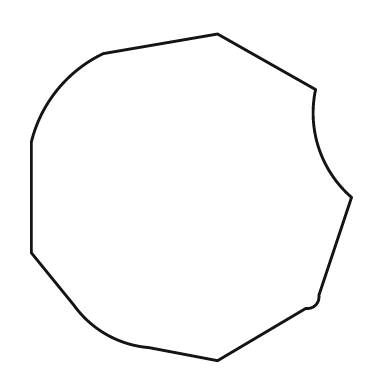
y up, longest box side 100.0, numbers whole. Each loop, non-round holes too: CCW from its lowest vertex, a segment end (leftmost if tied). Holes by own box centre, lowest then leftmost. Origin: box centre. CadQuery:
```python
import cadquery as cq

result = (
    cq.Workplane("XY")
    .moveTo(8.0, -50.0)
    .lineTo(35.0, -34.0)
    .threePointArc((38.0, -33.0), (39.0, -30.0))
    .lineTo(49.0, 0.0)
    .threePointArc((39.0, 15.0), (38.0, 33.0))
    .lineTo(8.0, 50.0)
    .lineTo(-27.0, 44.0)
    .threePointArc((-41.0, 33.0), (-49.0, 17.0))
    .lineTo(-49.0, -17.0)
    .lineTo(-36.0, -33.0)
    .threePointArc((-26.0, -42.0), (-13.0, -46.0))
    .close()
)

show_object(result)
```